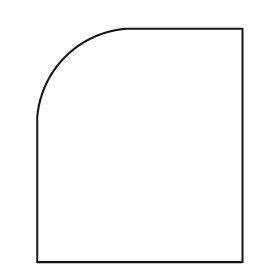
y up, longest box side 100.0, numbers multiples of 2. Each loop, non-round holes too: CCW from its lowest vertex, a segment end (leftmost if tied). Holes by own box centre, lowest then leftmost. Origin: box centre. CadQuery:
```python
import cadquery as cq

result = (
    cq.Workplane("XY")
    .moveTo(-44.0, -50.0)
    .lineTo(44.0, -50.0)
    .lineTo(44.0, 50.0)
    .lineTo(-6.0, 50.0)
    .threePointArc((-32.0, 38.0), (-44.0, 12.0))
    .close()
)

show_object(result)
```